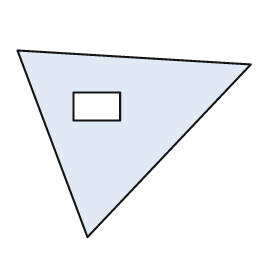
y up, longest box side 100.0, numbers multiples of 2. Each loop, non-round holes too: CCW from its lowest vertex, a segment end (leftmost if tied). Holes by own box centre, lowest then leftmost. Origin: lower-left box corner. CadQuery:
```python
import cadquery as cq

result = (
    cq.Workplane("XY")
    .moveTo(30.0, 0.0)
    .lineTo(100.0, 74.0)
    .lineTo(0.0, 80.0)
    .close()
    .moveTo(24.0, 50.0)
    .lineTo(44.0, 50.0)
    .lineTo(44.0, 62.0)
    .lineTo(24.0, 62.0)
    .close()
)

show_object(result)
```